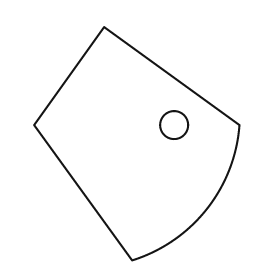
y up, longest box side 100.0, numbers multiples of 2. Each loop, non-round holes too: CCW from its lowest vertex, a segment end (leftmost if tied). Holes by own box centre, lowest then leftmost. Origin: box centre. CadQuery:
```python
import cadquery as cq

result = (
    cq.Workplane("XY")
    .moveTo(-2.0, -50.0)
    .threePointArc((30.0, -28.0), (44.0, 8.0))
    .lineTo(-14.0, 50.0)
    .lineTo(-44.0, 8.0)
    .close()
    .moveTo(16.0, 8.0)
    .circle(6.0)
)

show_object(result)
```